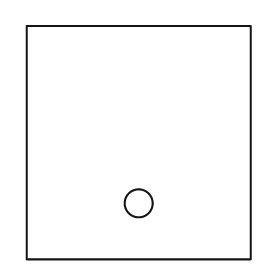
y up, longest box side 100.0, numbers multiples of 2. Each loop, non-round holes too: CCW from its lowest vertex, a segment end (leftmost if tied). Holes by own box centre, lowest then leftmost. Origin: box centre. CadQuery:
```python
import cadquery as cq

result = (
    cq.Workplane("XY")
    .moveTo(-48.0, -50.0)
    .lineTo(48.0, -50.0)
    .lineTo(48.0, 50.0)
    .lineTo(-48.0, 50.0)
    .close()
    .moveTo(0.0, -26.0)
    .circle(6.0)
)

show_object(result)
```